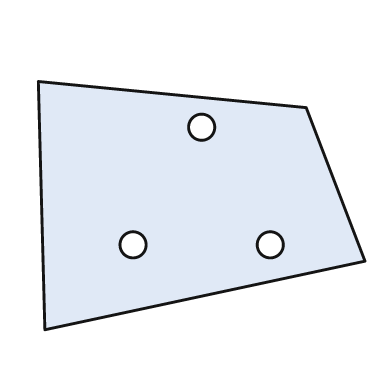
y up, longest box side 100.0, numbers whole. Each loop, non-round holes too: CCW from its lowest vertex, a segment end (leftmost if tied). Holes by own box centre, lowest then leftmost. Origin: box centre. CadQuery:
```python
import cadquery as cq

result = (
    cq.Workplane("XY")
    .moveTo(-48.0, -38.0)
    .lineTo(50.0, -17.0)
    .lineTo(32.0, 30.0)
    .lineTo(-50.0, 38.0)
    .close()
    .moveTo(-21.0, -12.0)
    .circle(4.0)
    .moveTo(21.0, -12.0)
    .circle(4.0)
    .moveTo(0.0, 24.0)
    .circle(4.0)
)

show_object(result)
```